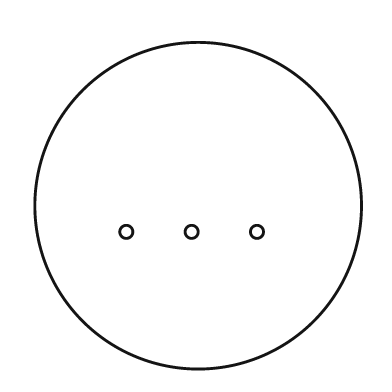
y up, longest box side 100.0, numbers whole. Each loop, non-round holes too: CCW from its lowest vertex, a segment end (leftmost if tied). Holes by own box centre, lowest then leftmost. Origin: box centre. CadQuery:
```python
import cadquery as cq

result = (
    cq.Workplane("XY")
    .moveTo(0.0, 0.0)
    .circle(50.0)
    .moveTo(-22.0, -8.0)
    .circle(2.0)
    .moveTo(-2.0, -8.0)
    .circle(2.0)
    .moveTo(18.0, -8.0)
    .circle(2.0)
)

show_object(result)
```